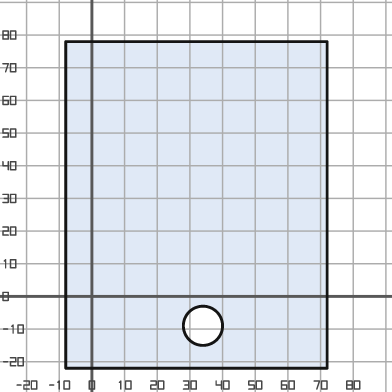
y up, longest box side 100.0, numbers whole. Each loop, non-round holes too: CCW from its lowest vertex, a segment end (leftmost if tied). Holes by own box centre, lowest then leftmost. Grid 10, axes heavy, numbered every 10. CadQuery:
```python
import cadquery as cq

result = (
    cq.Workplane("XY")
    .moveTo(-8.0, -22.0)
    .lineTo(72.0, -22.0)
    .lineTo(72.0, 78.0)
    .lineTo(-8.0, 78.0)
    .close()
    .moveTo(34.0, -9.0)
    .circle(6.0)
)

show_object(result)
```